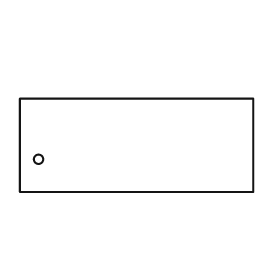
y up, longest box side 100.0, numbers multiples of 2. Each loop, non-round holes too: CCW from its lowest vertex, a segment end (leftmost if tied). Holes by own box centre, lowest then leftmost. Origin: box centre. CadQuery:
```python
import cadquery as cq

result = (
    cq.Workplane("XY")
    .moveTo(-50.0, -20.0)
    .lineTo(50.0, -20.0)
    .lineTo(50.0, 20.0)
    .lineTo(-50.0, 20.0)
    .close()
    .moveTo(-42.0, -6.0)
    .circle(2.0)
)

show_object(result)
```